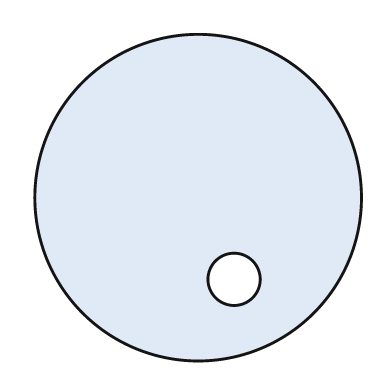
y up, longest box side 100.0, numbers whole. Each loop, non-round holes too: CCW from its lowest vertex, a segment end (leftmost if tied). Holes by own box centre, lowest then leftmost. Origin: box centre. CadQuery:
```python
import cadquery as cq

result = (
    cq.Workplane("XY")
    .moveTo(0.0, 0.0)
    .circle(50.0)
    .moveTo(11.0, -25.0)
    .circle(8.0)
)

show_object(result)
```